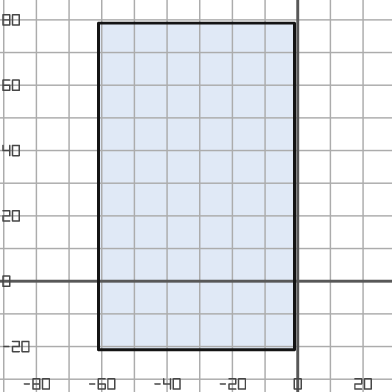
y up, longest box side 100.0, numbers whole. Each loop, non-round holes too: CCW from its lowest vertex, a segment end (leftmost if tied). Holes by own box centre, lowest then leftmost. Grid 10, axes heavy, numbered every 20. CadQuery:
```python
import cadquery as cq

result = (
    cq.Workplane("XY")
    .moveTo(-61.0, -21.0)
    .lineTo(-1.0, -21.0)
    .lineTo(-1.0, 79.0)
    .lineTo(-61.0, 79.0)
    .close()
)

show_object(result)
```